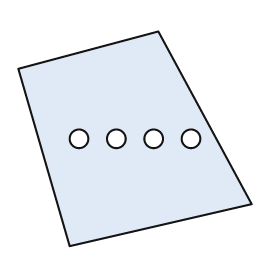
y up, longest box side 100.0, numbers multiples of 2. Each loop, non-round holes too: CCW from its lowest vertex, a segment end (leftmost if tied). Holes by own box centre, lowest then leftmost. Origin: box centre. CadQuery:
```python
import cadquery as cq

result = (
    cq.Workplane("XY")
    .moveTo(-28.0, -46.0)
    .lineTo(50.0, -28.0)
    .lineTo(10.0, 46.0)
    .lineTo(-50.0, 30.0)
    .close()
    .moveTo(-24.0, 0.0)
    .circle(4.0)
    .moveTo(-8.0, 0.0)
    .circle(4.0)
    .moveTo(8.0, 0.0)
    .circle(4.0)
    .moveTo(24.0, 0.0)
    .circle(4.0)
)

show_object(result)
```